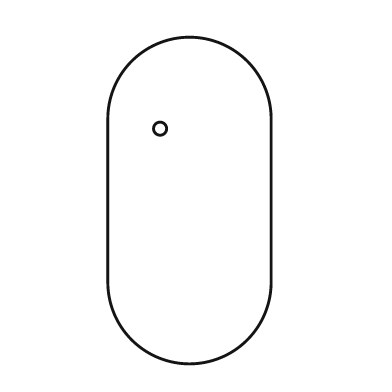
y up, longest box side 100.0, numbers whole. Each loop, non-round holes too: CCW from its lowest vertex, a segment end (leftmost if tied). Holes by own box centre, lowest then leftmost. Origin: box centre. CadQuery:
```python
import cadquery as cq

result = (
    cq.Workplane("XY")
    .moveTo(-25.0, -25.0)
    .threePointArc((0.0, -50.0), (25.0, -25.0))
    .lineTo(25.0, 25.0)
    .threePointArc((0.0, 50.0), (-25.0, 25.0))
    .close()
    .moveTo(-9.0, 22.0)
    .circle(2.0)
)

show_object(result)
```